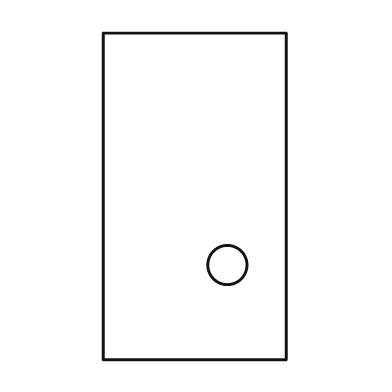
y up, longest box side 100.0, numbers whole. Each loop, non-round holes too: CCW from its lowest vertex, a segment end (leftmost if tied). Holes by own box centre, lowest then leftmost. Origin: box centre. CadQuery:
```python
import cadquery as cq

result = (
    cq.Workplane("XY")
    .moveTo(-28.0, -50.0)
    .lineTo(28.0, -50.0)
    .lineTo(28.0, 50.0)
    .lineTo(-28.0, 50.0)
    .close()
    .moveTo(10.0, -21.0)
    .circle(6.0)
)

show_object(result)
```